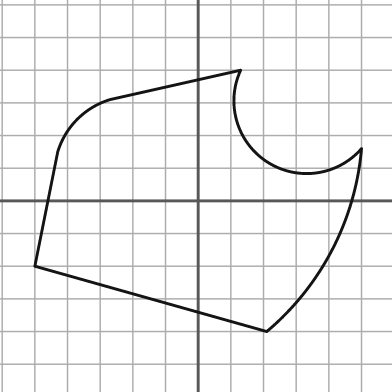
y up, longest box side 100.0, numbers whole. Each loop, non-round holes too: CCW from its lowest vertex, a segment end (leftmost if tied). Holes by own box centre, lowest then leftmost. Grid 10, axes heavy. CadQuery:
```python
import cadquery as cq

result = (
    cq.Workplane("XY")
    .moveTo(21.0, -40.0)
    .threePointArc((41.0, -15.0), (50.0, 16.0))
    .threePointArc((21.0, 12.0), (13.0, 40.0))
    .lineTo(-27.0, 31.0)
    .threePointArc((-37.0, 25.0), (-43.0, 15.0))
    .lineTo(-50.0, -20.0)
    .close()
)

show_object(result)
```